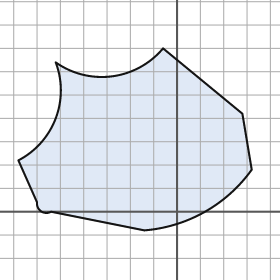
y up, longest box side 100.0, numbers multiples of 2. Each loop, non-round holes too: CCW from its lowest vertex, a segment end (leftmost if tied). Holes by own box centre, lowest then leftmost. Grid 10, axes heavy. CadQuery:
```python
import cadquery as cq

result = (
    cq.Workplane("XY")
    .moveTo(-14.0, -8.0)
    .threePointArc((12.0, 0.0), (32.0, 18.0))
    .lineTo(28.0, 42.0)
    .lineTo(-6.0, 70.0)
    .threePointArc((-28.0, 58.0), (-52.0, 64.0))
    .threePointArc((-52.0, 40.0), (-68.0, 22.0))
    .lineTo(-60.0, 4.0)
    .threePointArc((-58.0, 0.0), (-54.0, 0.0))
    .close()
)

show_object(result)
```